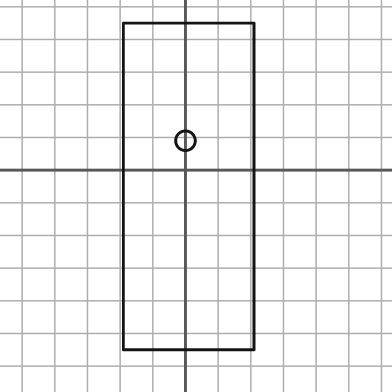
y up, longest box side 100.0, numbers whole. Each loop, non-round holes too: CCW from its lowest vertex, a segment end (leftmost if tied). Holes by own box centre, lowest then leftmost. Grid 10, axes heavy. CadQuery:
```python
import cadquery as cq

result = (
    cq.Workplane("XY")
    .moveTo(-19.0, -55.0)
    .lineTo(21.0, -55.0)
    .lineTo(21.0, 45.0)
    .lineTo(-19.0, 45.0)
    .close()
    .moveTo(0.0, 9.0)
    .circle(3.0)
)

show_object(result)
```